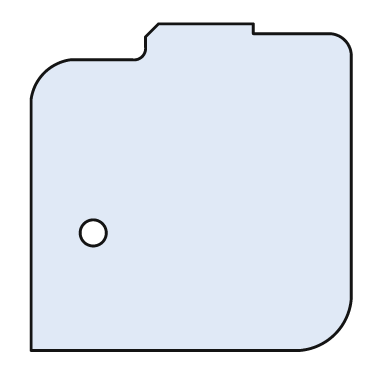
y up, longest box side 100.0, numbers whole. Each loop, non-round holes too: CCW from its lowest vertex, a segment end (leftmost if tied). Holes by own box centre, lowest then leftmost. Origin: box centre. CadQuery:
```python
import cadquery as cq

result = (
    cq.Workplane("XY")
    .moveTo(-49.0, -50.0)
    .lineTo(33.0, -50.0)
    .threePointArc((44.0, -45.0), (49.0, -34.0))
    .lineTo(49.0, 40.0)
    .threePointArc((47.0, 45.0), (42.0, 47.0))
    .lineTo(19.0, 47.0)
    .lineTo(19.0, 50.0)
    .lineTo(-10.0, 50.0)
    .lineTo(-14.0, 46.0)
    .lineTo(-14.0, 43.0)
    .threePointArc((-15.0, 40.0), (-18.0, 39.0))
    .lineTo(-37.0, 39.0)
    .threePointArc((-45.0, 35.0), (-49.0, 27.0))
    .close()
    .moveTo(-30.0, -14.0)
    .circle(4.0)
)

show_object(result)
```